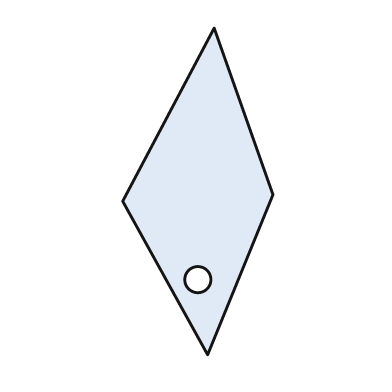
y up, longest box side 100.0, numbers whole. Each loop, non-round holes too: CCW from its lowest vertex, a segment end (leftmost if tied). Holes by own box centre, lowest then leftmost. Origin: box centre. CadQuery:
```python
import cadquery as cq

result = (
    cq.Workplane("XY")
    .moveTo(3.0, -50.0)
    .lineTo(23.0, -1.0)
    .lineTo(5.0, 50.0)
    .lineTo(-23.0, -3.0)
    .close()
    .moveTo(0.0, -27.0)
    .circle(4.0)
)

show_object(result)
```